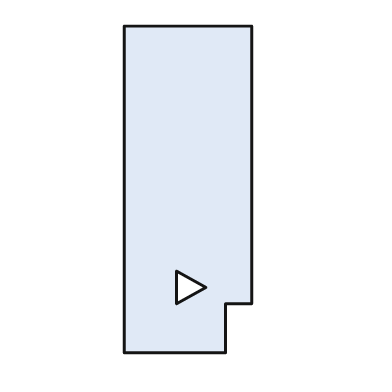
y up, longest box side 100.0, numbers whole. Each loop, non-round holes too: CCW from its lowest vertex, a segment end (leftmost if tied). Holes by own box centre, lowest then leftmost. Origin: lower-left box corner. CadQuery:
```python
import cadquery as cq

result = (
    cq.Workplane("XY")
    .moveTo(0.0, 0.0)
    .lineTo(31.0, 0.0)
    .lineTo(31.0, 15.0)
    .lineTo(39.0, 15.0)
    .lineTo(39.0, 100.0)
    .lineTo(0.0, 100.0)
    .close()
    .moveTo(16.0, 15.0)
    .lineTo(25.0, 20.0)
    .lineTo(16.0, 25.0)
    .close()
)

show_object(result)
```